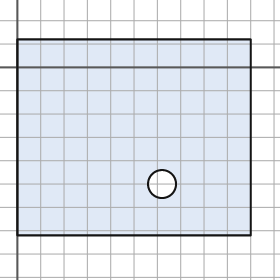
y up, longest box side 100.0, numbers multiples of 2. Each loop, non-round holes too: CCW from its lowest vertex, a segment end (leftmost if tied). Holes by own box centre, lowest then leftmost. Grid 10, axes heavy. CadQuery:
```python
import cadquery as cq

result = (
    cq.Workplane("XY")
    .moveTo(0.0, -72.0)
    .lineTo(100.0, -72.0)
    .lineTo(100.0, 12.0)
    .lineTo(0.0, 12.0)
    .close()
    .moveTo(62.0, -50.0)
    .circle(6.0)
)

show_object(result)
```